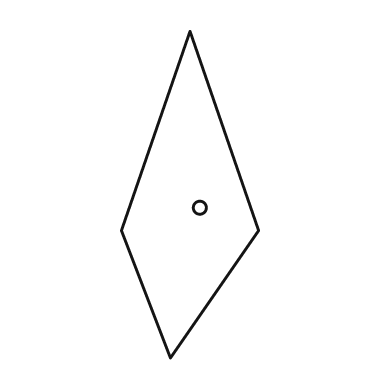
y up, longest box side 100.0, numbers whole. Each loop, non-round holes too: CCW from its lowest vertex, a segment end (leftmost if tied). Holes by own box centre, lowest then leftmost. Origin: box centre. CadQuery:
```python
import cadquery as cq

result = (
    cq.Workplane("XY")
    .moveTo(-6.0, -50.0)
    .lineTo(21.0, -11.0)
    .lineTo(0.0, 50.0)
    .lineTo(-21.0, -11.0)
    .close()
    .moveTo(3.0, -4.0)
    .circle(2.0)
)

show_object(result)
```